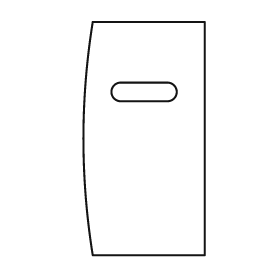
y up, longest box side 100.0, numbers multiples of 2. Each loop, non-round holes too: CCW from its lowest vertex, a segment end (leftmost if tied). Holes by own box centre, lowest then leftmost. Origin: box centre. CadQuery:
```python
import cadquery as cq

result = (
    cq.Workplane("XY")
    .moveTo(-22.0, -50.0)
    .lineTo(26.0, -50.0)
    .lineTo(26.0, 50.0)
    .lineTo(-22.0, 50.0)
    .threePointArc((-26.0, 0.0), (-22.0, -50.0))
    .close()
    .moveTo(-10.0, 16.0)
    .lineTo(10.0, 16.0)
    .threePointArc((14.0, 20.0), (10.0, 24.0))
    .lineTo(-10.0, 24.0)
    .threePointArc((-14.0, 20.0), (-10.0, 16.0))
    .close()
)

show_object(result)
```